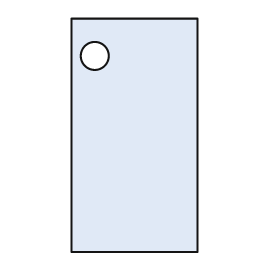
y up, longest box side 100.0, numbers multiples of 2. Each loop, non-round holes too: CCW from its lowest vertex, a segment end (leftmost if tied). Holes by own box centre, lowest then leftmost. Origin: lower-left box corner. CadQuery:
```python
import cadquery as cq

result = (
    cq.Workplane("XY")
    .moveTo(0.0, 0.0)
    .lineTo(54.0, 0.0)
    .lineTo(54.0, 100.0)
    .lineTo(0.0, 100.0)
    .close()
    .moveTo(10.0, 84.0)
    .circle(6.0)
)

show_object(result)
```